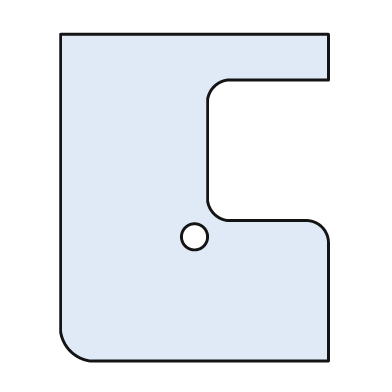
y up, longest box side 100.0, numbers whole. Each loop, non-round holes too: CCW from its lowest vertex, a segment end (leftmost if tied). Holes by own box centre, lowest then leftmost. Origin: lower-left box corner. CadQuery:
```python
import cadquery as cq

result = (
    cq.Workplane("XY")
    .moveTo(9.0, 0.0)
    .lineTo(82.0, 0.0)
    .lineTo(82.0, 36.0)
    .threePointArc((80.0, 41.0), (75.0, 43.0))
    .lineTo(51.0, 43.0)
    .threePointArc((47.0, 45.0), (45.0, 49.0))
    .lineTo(45.0, 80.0)
    .threePointArc((47.0, 84.0), (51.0, 86.0))
    .lineTo(82.0, 86.0)
    .lineTo(82.0, 100.0)
    .lineTo(0.0, 100.0)
    .lineTo(0.0, 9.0)
    .threePointArc((3.0, 3.0), (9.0, 0.0))
    .close()
    .moveTo(41.0, 38.0)
    .circle(4.0)
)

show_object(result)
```